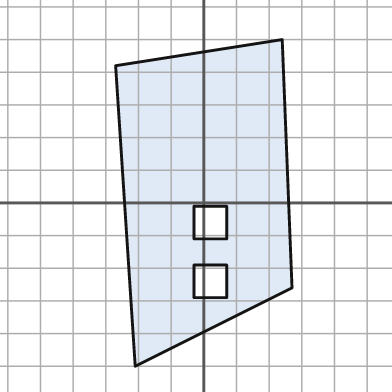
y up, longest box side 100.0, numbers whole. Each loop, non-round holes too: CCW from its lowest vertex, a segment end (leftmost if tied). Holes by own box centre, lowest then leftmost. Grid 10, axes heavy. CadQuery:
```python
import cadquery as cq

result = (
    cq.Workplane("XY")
    .moveTo(-21.0, -50.0)
    .lineTo(27.0, -26.0)
    .lineTo(24.0, 50.0)
    .lineTo(-27.0, 42.0)
    .close()
    .moveTo(-3.0, -29.0)
    .lineTo(7.0, -29.0)
    .lineTo(7.0, -19.0)
    .lineTo(-3.0, -19.0)
    .close()
    .moveTo(-3.0, -11.0)
    .lineTo(7.0, -11.0)
    .lineTo(7.0, -1.0)
    .lineTo(-3.0, -1.0)
    .close()
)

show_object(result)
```